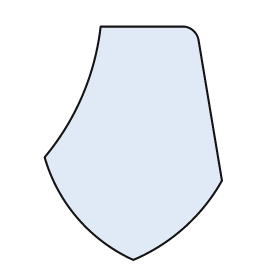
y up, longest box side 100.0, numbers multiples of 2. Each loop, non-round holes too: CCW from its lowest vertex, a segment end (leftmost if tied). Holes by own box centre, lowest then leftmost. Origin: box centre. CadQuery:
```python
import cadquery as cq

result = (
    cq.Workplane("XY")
    .moveTo(0.0, -50.0)
    .threePointArc((22.0, -36.0), (38.0, -16.0))
    .lineTo(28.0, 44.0)
    .threePointArc((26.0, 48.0), (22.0, 50.0))
    .lineTo(-14.0, 50.0)
    .threePointArc((-22.0, 20.0), (-38.0, -6.0))
    .threePointArc((-24.0, -32.0), (0.0, -50.0))
    .close()
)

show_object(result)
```